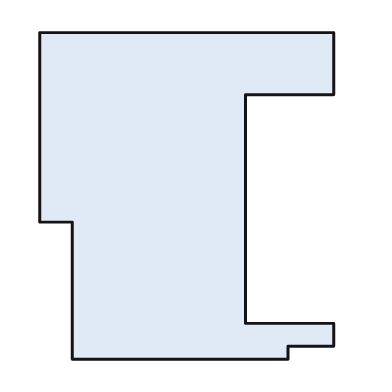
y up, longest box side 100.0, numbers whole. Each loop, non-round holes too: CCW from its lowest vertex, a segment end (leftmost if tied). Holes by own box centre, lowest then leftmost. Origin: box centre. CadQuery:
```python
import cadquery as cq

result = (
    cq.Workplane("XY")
    .moveTo(-35.0, -50.0)
    .lineTo(31.0, -50.0)
    .lineTo(31.0, -46.0)
    .lineTo(45.0, -46.0)
    .lineTo(45.0, -39.0)
    .lineTo(18.0, -39.0)
    .lineTo(18.0, 31.0)
    .lineTo(45.0, 31.0)
    .lineTo(45.0, 50.0)
    .lineTo(-45.0, 50.0)
    .lineTo(-45.0, -8.0)
    .lineTo(-35.0, -8.0)
    .close()
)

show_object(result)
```